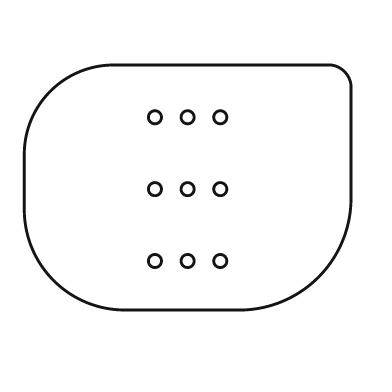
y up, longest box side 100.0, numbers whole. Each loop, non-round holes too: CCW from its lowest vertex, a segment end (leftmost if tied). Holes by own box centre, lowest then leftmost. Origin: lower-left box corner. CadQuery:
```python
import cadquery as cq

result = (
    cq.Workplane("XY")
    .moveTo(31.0, 0.0)
    .lineTo(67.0, 0.0)
    .threePointArc((90.0, 10.0), (100.0, 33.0))
    .lineTo(100.0, 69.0)
    .threePointArc((98.0, 73.0), (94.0, 75.0))
    .lineTo(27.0, 75.0)
    .threePointArc((8.0, 67.0), (0.0, 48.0))
    .lineTo(0.0, 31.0)
    .threePointArc((9.0, 9.0), (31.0, 0.0))
    .close()
    .moveTo(40.0, 15.0)
    .circle(2.0)
    .moveTo(50.0, 15.0)
    .circle(2.0)
    .moveTo(60.0, 15.0)
    .circle(2.0)
    .moveTo(40.0, 37.0)
    .circle(2.0)
    .moveTo(50.0, 37.0)
    .circle(2.0)
    .moveTo(60.0, 37.0)
    .circle(2.0)
    .moveTo(40.0, 59.0)
    .circle(2.0)
    .moveTo(50.0, 59.0)
    .circle(2.0)
    .moveTo(60.0, 59.0)
    .circle(2.0)
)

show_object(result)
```